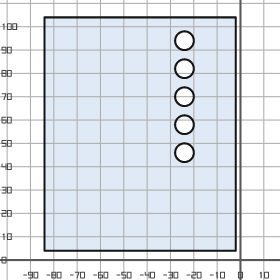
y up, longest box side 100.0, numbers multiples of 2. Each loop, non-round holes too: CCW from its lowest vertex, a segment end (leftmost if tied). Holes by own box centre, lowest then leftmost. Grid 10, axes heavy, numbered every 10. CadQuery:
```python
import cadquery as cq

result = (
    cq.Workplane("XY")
    .moveTo(-84.0, 4.0)
    .lineTo(-2.0, 4.0)
    .lineTo(-2.0, 104.0)
    .lineTo(-84.0, 104.0)
    .close()
    .moveTo(-24.0, 46.0)
    .circle(4.0)
    .moveTo(-24.0, 58.0)
    .circle(4.0)
    .moveTo(-24.0, 70.0)
    .circle(4.0)
    .moveTo(-24.0, 82.0)
    .circle(4.0)
    .moveTo(-24.0, 94.0)
    .circle(4.0)
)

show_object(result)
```